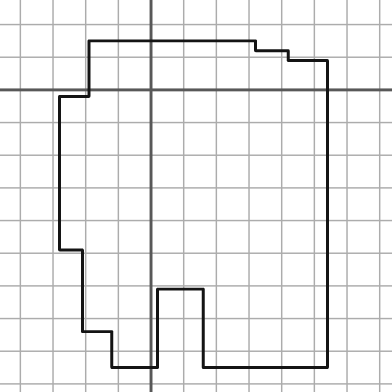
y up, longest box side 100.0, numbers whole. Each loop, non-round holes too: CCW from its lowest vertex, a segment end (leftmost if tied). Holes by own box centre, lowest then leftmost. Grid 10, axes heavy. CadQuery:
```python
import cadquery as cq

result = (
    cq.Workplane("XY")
    .moveTo(-12.0, -85.0)
    .lineTo(2.0, -85.0)
    .lineTo(2.0, -61.0)
    .lineTo(16.0, -61.0)
    .lineTo(16.0, -85.0)
    .lineTo(54.0, -85.0)
    .lineTo(54.0, 9.0)
    .lineTo(42.0, 9.0)
    .lineTo(42.0, 12.0)
    .lineTo(32.0, 12.0)
    .lineTo(32.0, 15.0)
    .lineTo(-19.0, 15.0)
    .lineTo(-19.0, -2.0)
    .lineTo(-28.0, -2.0)
    .lineTo(-28.0, -49.0)
    .lineTo(-21.0, -49.0)
    .lineTo(-21.0, -74.0)
    .lineTo(-12.0, -74.0)
    .close()
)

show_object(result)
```